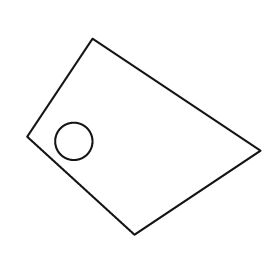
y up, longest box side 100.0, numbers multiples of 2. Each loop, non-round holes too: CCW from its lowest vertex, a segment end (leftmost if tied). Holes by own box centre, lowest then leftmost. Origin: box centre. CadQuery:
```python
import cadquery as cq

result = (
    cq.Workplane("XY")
    .moveTo(-4.0, -42.0)
    .lineTo(50.0, -6.0)
    .lineTo(-22.0, 42.0)
    .lineTo(-50.0, 0.0)
    .close()
    .moveTo(-30.0, -2.0)
    .circle(8.0)
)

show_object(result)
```